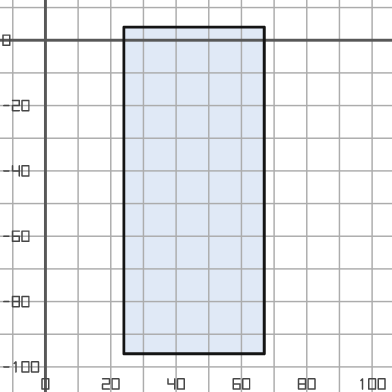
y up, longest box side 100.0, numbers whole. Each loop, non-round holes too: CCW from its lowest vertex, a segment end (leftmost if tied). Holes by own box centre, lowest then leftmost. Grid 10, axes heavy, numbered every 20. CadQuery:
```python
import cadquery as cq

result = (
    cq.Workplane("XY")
    .moveTo(24.0, -96.0)
    .lineTo(67.0, -96.0)
    .lineTo(67.0, 4.0)
    .lineTo(24.0, 4.0)
    .close()
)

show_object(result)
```